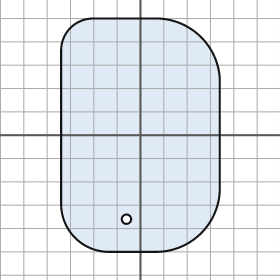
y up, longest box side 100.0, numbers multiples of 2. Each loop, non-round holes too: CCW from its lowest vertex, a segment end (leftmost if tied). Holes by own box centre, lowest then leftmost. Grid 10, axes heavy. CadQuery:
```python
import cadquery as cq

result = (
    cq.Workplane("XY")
    .moveTo(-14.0, -50.0)
    .lineTo(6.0, -50.0)
    .threePointArc((26.0, -42.0), (34.0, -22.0))
    .lineTo(34.0, 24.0)
    .threePointArc((26.0, 42.0), (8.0, 50.0))
    .lineTo(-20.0, 50.0)
    .threePointArc((-30.0, 46.0), (-34.0, 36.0))
    .lineTo(-34.0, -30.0)
    .threePointArc((-28.0, -44.0), (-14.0, -50.0))
    .close()
    .moveTo(-6.0, -36.0)
    .circle(2.0)
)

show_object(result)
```